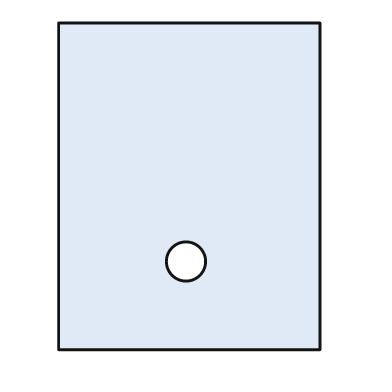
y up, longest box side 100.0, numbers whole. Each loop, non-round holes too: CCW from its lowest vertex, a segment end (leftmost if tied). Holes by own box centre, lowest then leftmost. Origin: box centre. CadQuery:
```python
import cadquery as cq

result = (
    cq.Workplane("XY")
    .moveTo(-40.0, -50.0)
    .lineTo(40.0, -50.0)
    .lineTo(40.0, 50.0)
    .lineTo(-40.0, 50.0)
    .close()
    .moveTo(-1.0, -23.0)
    .circle(6.0)
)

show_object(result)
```